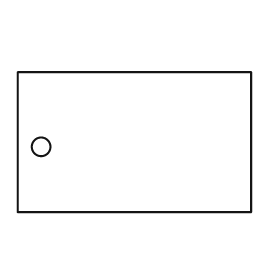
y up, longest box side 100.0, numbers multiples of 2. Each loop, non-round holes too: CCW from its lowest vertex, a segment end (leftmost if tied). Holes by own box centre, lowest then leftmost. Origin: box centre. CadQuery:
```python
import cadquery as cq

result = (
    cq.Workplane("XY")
    .moveTo(-50.0, -30.0)
    .lineTo(50.0, -30.0)
    .lineTo(50.0, 30.0)
    .lineTo(-50.0, 30.0)
    .close()
    .moveTo(-40.0, -2.0)
    .circle(4.0)
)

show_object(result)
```